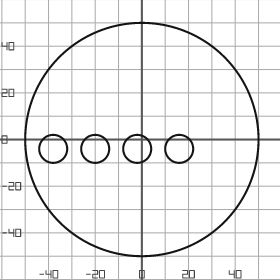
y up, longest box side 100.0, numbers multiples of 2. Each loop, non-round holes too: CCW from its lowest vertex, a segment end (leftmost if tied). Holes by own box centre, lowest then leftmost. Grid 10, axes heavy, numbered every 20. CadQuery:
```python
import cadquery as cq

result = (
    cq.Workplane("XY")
    .moveTo(0.0, 0.0)
    .circle(50.0)
    .moveTo(-38.0, -4.0)
    .circle(6.0)
    .moveTo(-20.0, -4.0)
    .circle(6.0)
    .moveTo(-2.0, -4.0)
    .circle(6.0)
    .moveTo(16.0, -4.0)
    .circle(6.0)
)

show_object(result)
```